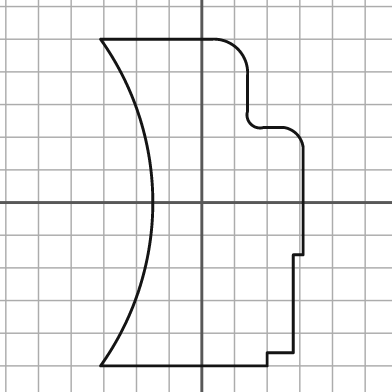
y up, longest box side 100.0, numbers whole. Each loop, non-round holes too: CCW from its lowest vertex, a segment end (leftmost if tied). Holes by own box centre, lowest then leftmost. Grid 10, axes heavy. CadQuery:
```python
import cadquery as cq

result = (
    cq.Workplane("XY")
    .moveTo(-31.0, -50.0)
    .lineTo(20.0, -50.0)
    .lineTo(20.0, -46.0)
    .lineTo(28.0, -46.0)
    .lineTo(28.0, -16.0)
    .lineTo(31.0, -16.0)
    .lineTo(31.0, 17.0)
    .threePointArc((29.0, 21.0), (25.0, 23.0))
    .lineTo(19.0, 23.0)
    .threePointArc((15.0, 24.0), (14.0, 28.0))
    .lineTo(14.0, 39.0)
    .threePointArc((11.0, 47.0), (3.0, 50.0))
    .lineTo(-31.0, 50.0)
    .threePointArc((-15.0, 0.0), (-31.0, -50.0))
    .close()
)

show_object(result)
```